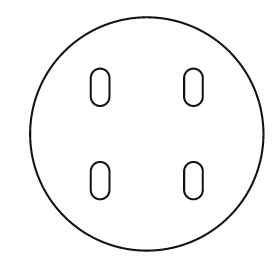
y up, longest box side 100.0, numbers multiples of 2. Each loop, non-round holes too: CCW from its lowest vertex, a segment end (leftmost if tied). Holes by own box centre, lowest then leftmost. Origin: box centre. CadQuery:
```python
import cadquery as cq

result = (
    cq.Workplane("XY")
    .moveTo(0.0, 0.0)
    .circle(50.0)
    .moveTo(-24.0, -24.0)
    .threePointArc((-20.0, -28.0), (-16.0, -24.0))
    .lineTo(-16.0, -16.0)
    .threePointArc((-20.0, -12.0), (-24.0, -16.0))
    .close()
    .moveTo(16.0, -24.0)
    .threePointArc((20.0, -28.0), (24.0, -24.0))
    .lineTo(24.0, -16.0)
    .threePointArc((20.0, -12.0), (16.0, -16.0))
    .close()
    .moveTo(-24.0, 16.0)
    .threePointArc((-20.0, 12.0), (-16.0, 16.0))
    .lineTo(-16.0, 24.0)
    .threePointArc((-20.0, 28.0), (-24.0, 24.0))
    .close()
    .moveTo(16.0, 16.0)
    .threePointArc((20.0, 12.0), (24.0, 16.0))
    .lineTo(24.0, 24.0)
    .threePointArc((20.0, 28.0), (16.0, 24.0))
    .close()
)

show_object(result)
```